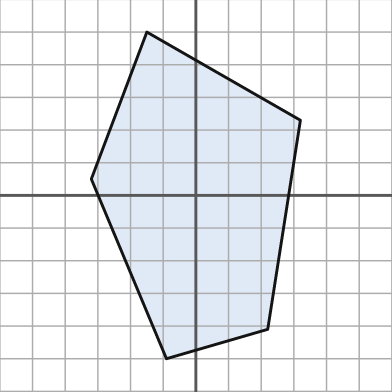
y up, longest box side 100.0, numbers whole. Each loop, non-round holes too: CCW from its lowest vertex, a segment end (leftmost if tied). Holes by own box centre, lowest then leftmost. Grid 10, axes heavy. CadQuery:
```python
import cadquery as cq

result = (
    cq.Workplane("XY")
    .moveTo(-9.0, -50.0)
    .lineTo(22.0, -41.0)
    .lineTo(32.0, 23.0)
    .lineTo(-15.0, 50.0)
    .lineTo(-32.0, 5.0)
    .close()
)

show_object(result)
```